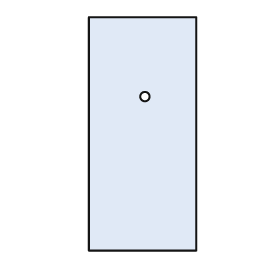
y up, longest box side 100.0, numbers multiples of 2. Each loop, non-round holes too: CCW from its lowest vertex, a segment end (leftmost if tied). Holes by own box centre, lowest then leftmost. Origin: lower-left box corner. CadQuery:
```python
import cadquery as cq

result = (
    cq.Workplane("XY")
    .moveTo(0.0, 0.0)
    .lineTo(46.0, 0.0)
    .lineTo(46.0, 100.0)
    .lineTo(0.0, 100.0)
    .close()
    .moveTo(24.0, 66.0)
    .circle(2.0)
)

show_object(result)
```